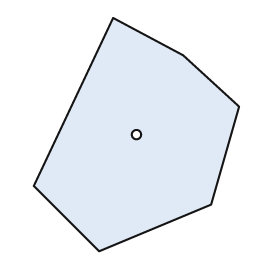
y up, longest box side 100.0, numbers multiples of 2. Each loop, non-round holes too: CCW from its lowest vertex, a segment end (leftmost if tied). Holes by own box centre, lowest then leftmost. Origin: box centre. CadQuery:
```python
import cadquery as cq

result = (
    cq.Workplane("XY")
    .moveTo(-16.0, -50.0)
    .lineTo(32.0, -30.0)
    .lineTo(44.0, 12.0)
    .lineTo(20.0, 34.0)
    .lineTo(-10.0, 50.0)
    .lineTo(-44.0, -22.0)
    .close()
    .moveTo(0.0, 0.0)
    .circle(2.0)
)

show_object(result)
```